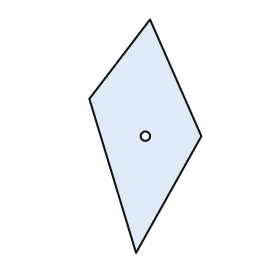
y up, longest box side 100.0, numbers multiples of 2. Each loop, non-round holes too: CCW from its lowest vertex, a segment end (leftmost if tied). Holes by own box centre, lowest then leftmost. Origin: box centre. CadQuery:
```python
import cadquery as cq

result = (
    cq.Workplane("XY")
    .moveTo(-4.0, -50.0)
    .lineTo(24.0, 0.0)
    .lineTo(2.0, 50.0)
    .lineTo(-24.0, 16.0)
    .close()
    .moveTo(0.0, 0.0)
    .circle(2.0)
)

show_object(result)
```